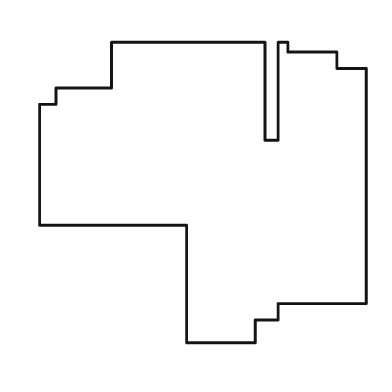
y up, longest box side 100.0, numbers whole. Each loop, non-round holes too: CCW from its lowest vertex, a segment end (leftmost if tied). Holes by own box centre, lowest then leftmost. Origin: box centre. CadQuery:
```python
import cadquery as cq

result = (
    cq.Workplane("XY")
    .moveTo(-5.0, -46.0)
    .lineTo(16.0, -46.0)
    .lineTo(16.0, -39.0)
    .lineTo(23.0, -39.0)
    .lineTo(23.0, -34.0)
    .lineTo(50.0, -34.0)
    .lineTo(50.0, 38.0)
    .lineTo(41.0, 38.0)
    .lineTo(41.0, 43.0)
    .lineTo(26.0, 43.0)
    .lineTo(26.0, 46.0)
    .lineTo(23.0, 46.0)
    .lineTo(23.0, 16.0)
    .lineTo(19.0, 16.0)
    .lineTo(19.0, 46.0)
    .lineTo(-28.0, 46.0)
    .lineTo(-28.0, 32.0)
    .lineTo(-45.0, 32.0)
    .lineTo(-45.0, 27.0)
    .lineTo(-50.0, 27.0)
    .lineTo(-50.0, -10.0)
    .lineTo(-5.0, -10.0)
    .close()
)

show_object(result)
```